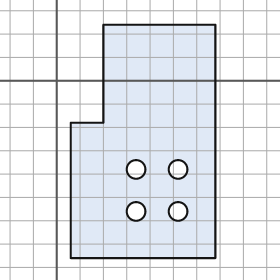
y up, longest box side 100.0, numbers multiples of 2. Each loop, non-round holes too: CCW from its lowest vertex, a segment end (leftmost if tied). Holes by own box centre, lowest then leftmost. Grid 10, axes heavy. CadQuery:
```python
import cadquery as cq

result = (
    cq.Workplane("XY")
    .moveTo(6.0, -76.0)
    .lineTo(68.0, -76.0)
    .lineTo(68.0, 24.0)
    .lineTo(20.0, 24.0)
    .lineTo(20.0, -18.0)
    .lineTo(6.0, -18.0)
    .close()
    .moveTo(34.0, -56.0)
    .circle(4.0)
    .moveTo(52.0, -56.0)
    .circle(4.0)
    .moveTo(34.0, -38.0)
    .circle(4.0)
    .moveTo(52.0, -38.0)
    .circle(4.0)
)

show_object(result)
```